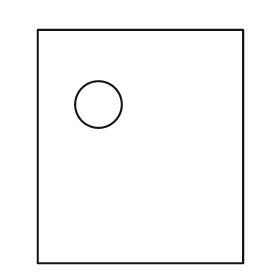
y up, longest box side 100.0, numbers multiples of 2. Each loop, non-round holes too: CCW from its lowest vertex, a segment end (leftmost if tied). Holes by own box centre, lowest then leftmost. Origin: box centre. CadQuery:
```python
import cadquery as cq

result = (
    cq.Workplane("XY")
    .moveTo(-44.0, -50.0)
    .lineTo(44.0, -50.0)
    .lineTo(44.0, 50.0)
    .lineTo(-44.0, 50.0)
    .close()
    .moveTo(-18.0, 18.0)
    .circle(10.0)
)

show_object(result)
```